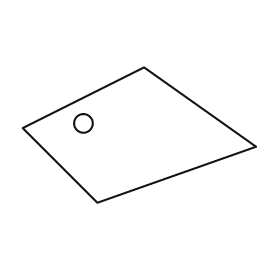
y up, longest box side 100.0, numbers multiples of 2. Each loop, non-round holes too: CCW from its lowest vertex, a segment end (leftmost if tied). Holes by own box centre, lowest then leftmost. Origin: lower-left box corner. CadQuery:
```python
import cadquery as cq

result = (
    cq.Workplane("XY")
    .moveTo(32.0, 0.0)
    .lineTo(100.0, 24.0)
    .lineTo(52.0, 58.0)
    .lineTo(0.0, 32.0)
    .close()
    .moveTo(26.0, 34.0)
    .circle(4.0)
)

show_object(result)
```